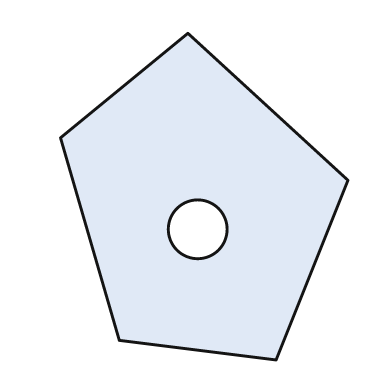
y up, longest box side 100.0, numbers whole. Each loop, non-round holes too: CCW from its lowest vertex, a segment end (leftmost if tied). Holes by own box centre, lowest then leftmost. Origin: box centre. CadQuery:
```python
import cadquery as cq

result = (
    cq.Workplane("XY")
    .moveTo(22.0, -50.0)
    .lineTo(44.0, 5.0)
    .lineTo(-5.0, 50.0)
    .lineTo(-44.0, 18.0)
    .lineTo(-26.0, -44.0)
    .close()
    .moveTo(-2.0, -10.0)
    .circle(9.0)
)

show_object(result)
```